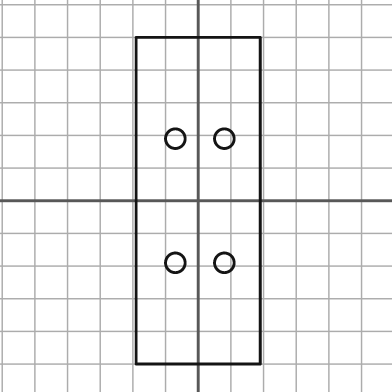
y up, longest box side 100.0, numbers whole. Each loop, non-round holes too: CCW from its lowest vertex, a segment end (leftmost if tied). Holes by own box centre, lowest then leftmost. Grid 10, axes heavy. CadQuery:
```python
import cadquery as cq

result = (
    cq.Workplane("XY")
    .moveTo(-19.0, -50.0)
    .lineTo(19.0, -50.0)
    .lineTo(19.0, 50.0)
    .lineTo(-19.0, 50.0)
    .close()
    .moveTo(-7.0, -19.0)
    .circle(3.0)
    .moveTo(8.0, -19.0)
    .circle(3.0)
    .moveTo(-7.0, 19.0)
    .circle(3.0)
    .moveTo(8.0, 19.0)
    .circle(3.0)
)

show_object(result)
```